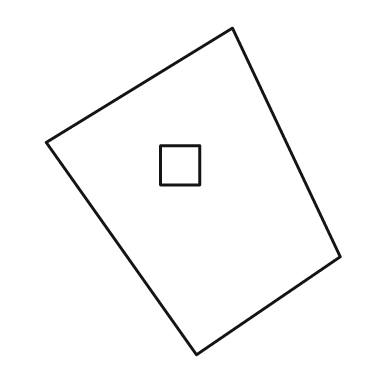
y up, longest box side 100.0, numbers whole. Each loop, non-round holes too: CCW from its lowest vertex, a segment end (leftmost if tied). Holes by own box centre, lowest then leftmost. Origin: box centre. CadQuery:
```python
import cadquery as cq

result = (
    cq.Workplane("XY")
    .moveTo(1.0, -50.0)
    .lineTo(45.0, -20.0)
    .lineTo(12.0, 50.0)
    .lineTo(-45.0, 15.0)
    .close()
    .moveTo(-10.0, 2.0)
    .lineTo(2.0, 2.0)
    .lineTo(2.0, 14.0)
    .lineTo(-10.0, 14.0)
    .close()
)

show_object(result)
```